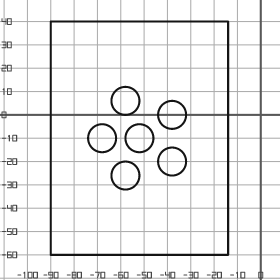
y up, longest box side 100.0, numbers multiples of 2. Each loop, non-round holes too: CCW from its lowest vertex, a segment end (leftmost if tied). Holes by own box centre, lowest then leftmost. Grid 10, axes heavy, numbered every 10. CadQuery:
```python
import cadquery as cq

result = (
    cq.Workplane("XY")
    .moveTo(-90.0, -60.0)
    .lineTo(-14.0, -60.0)
    .lineTo(-14.0, 40.0)
    .lineTo(-90.0, 40.0)
    .close()
    .moveTo(-58.0, -26.0)
    .circle(6.0)
    .moveTo(-38.0, -20.0)
    .circle(6.0)
    .moveTo(-68.0, -10.0)
    .circle(6.0)
    .moveTo(-52.0, -10.0)
    .circle(6.0)
    .moveTo(-38.0, 0.0)
    .circle(6.0)
    .moveTo(-58.0, 6.0)
    .circle(6.0)
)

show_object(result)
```